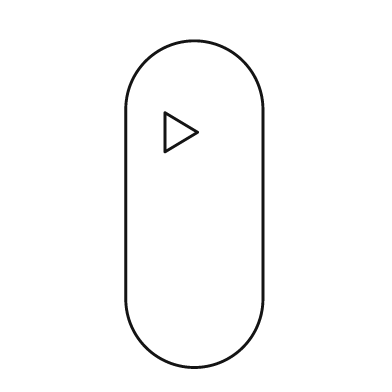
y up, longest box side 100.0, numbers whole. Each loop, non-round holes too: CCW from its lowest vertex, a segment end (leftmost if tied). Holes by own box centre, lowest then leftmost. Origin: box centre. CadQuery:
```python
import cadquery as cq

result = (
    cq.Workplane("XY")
    .moveTo(-21.0, -29.0)
    .threePointArc((0.0, -50.0), (21.0, -29.0))
    .lineTo(21.0, 29.0)
    .threePointArc((0.0, 50.0), (-21.0, 29.0))
    .close()
    .moveTo(-9.0, 16.0)
    .lineTo(1.0, 22.0)
    .lineTo(-9.0, 28.0)
    .close()
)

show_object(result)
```